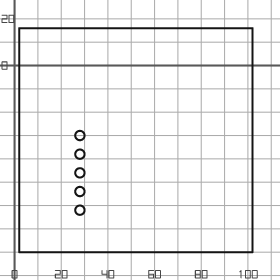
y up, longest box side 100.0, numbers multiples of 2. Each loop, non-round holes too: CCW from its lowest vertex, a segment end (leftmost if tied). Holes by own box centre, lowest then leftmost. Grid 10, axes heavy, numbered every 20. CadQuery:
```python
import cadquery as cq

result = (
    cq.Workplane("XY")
    .moveTo(2.0, -80.0)
    .lineTo(102.0, -80.0)
    .lineTo(102.0, 16.0)
    .lineTo(2.0, 16.0)
    .close()
    .moveTo(28.0, -62.0)
    .circle(2.0)
    .moveTo(28.0, -54.0)
    .circle(2.0)
    .moveTo(28.0, -46.0)
    .circle(2.0)
    .moveTo(28.0, -38.0)
    .circle(2.0)
    .moveTo(28.0, -30.0)
    .circle(2.0)
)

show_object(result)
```